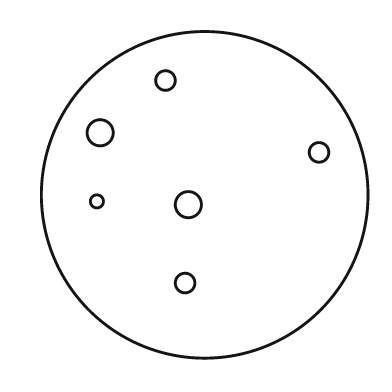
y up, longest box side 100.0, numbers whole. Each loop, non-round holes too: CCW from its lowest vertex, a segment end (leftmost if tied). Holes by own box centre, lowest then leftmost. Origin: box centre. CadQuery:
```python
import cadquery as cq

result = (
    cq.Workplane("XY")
    .moveTo(0.0, 0.0)
    .circle(50.0)
    .moveTo(-6.0, -27.0)
    .circle(3.0)
    .moveTo(-5.0, -3.0)
    .circle(4.0)
    .moveTo(-33.0, -2.0)
    .circle(2.0)
    .moveTo(35.0, 13.0)
    .circle(3.0)
    .moveTo(-32.0, 19.0)
    .circle(4.0)
    .moveTo(-12.0, 35.0)
    .circle(3.0)
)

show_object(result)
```